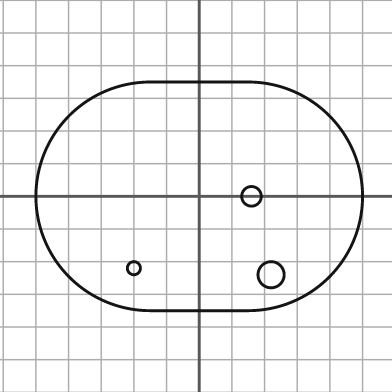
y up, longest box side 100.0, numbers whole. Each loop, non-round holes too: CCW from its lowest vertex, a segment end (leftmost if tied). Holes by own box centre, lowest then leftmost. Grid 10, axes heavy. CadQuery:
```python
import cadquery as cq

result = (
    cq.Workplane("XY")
    .moveTo(-15.0, -35.0)
    .lineTo(15.0, -35.0)
    .threePointArc((50.0, 0.0), (15.0, 35.0))
    .lineTo(-15.0, 35.0)
    .threePointArc((-50.0, 0.0), (-15.0, -35.0))
    .close()
    .moveTo(22.0, -24.0)
    .circle(4.0)
    .moveTo(-20.0, -22.0)
    .circle(2.0)
    .moveTo(16.0, 0.0)
    .circle(3.0)
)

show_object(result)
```